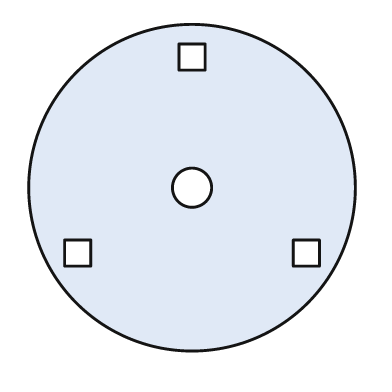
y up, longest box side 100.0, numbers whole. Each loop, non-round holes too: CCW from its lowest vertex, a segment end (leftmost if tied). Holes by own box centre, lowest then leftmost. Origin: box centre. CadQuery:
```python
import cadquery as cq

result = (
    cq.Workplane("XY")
    .moveTo(0.0, 0.0)
    .circle(50.0)
    .moveTo(-39.0, -24.0)
    .lineTo(-31.0, -24.0)
    .lineTo(-31.0, -16.0)
    .lineTo(-39.0, -16.0)
    .close()
    .moveTo(31.0, -24.0)
    .lineTo(39.0, -24.0)
    .lineTo(39.0, -16.0)
    .lineTo(31.0, -16.0)
    .close()
    .moveTo(0.0, 0.0)
    .circle(6.0)
    .moveTo(-4.0, 36.0)
    .lineTo(4.0, 36.0)
    .lineTo(4.0, 44.0)
    .lineTo(-4.0, 44.0)
    .close()
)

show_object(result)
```